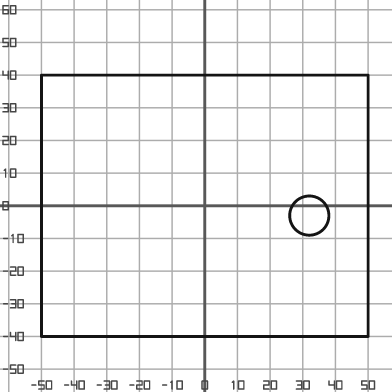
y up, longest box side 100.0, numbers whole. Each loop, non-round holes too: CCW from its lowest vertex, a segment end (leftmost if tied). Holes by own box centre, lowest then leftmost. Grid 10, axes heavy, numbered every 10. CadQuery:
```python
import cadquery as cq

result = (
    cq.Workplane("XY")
    .moveTo(-50.0, -40.0)
    .lineTo(50.0, -40.0)
    .lineTo(50.0, 40.0)
    .lineTo(-50.0, 40.0)
    .close()
    .moveTo(32.0, -3.0)
    .circle(6.0)
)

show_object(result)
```